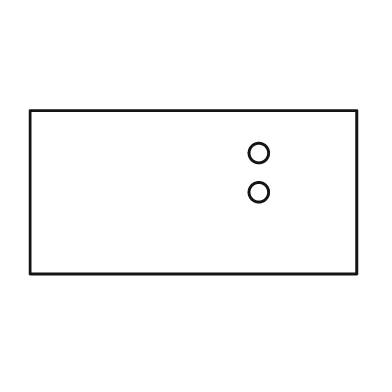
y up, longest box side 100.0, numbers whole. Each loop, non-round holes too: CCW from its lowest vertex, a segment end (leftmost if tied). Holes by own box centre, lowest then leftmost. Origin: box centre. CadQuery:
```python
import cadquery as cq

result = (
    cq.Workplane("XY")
    .moveTo(-50.0, -25.0)
    .lineTo(50.0, -25.0)
    .lineTo(50.0, 25.0)
    .lineTo(-50.0, 25.0)
    .close()
    .moveTo(20.0, 0.0)
    .circle(3.0)
    .moveTo(20.0, 12.0)
    .circle(3.0)
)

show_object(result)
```